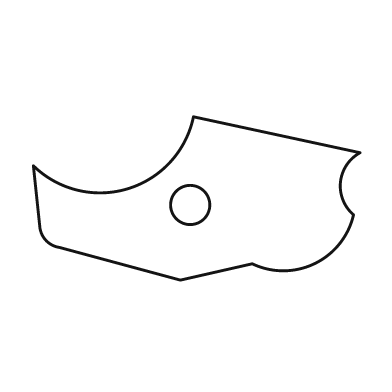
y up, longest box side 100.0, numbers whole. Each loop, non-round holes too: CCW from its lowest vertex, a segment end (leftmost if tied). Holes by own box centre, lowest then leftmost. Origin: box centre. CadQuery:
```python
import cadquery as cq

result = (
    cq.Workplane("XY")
    .moveTo(-5.0, -25.0)
    .lineTo(17.0, -20.0)
    .threePointArc((36.0, -20.0), (48.0, -5.0))
    .threePointArc((44.0, 5.0), (50.0, 14.0))
    .lineTo(-1.0, 25.0)
    .threePointArc((-21.0, 3.0), (-50.0, 10.0))
    .lineTo(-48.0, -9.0)
    .threePointArc((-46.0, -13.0), (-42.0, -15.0))
    .close()
    .moveTo(-2.0, -2.0)
    .circle(6.0)
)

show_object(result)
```